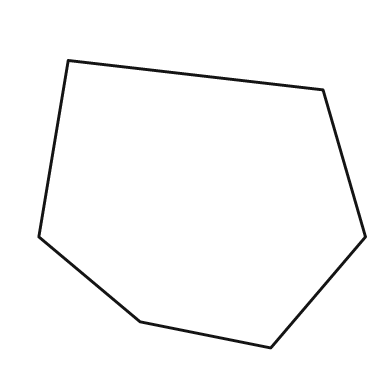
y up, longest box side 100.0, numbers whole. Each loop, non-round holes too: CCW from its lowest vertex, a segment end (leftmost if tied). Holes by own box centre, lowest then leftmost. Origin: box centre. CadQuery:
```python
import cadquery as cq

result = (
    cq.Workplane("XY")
    .moveTo(21.0, -44.0)
    .lineTo(50.0, -10.0)
    .lineTo(37.0, 35.0)
    .lineTo(-41.0, 44.0)
    .lineTo(-50.0, -10.0)
    .lineTo(-19.0, -36.0)
    .close()
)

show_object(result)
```